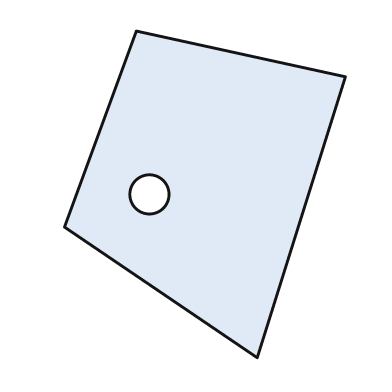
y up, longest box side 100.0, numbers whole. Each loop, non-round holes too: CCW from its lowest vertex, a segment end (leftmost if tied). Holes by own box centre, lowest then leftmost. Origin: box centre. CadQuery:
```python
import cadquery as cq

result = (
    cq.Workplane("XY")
    .moveTo(16.0, -50.0)
    .lineTo(43.0, 36.0)
    .lineTo(-21.0, 50.0)
    .lineTo(-43.0, -10.0)
    .close()
    .moveTo(-17.0, 0.0)
    .circle(6.0)
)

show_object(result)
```